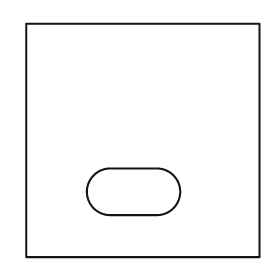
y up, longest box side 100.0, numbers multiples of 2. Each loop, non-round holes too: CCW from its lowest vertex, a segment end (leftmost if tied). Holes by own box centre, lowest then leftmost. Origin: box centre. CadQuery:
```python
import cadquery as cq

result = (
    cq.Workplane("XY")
    .moveTo(-50.0, -50.0)
    .lineTo(50.0, -50.0)
    .lineTo(50.0, 50.0)
    .lineTo(-50.0, 50.0)
    .close()
    .moveTo(-14.0, -32.0)
    .lineTo(6.0, -32.0)
    .threePointArc((16.0, -22.0), (6.0, -12.0))
    .lineTo(-14.0, -12.0)
    .threePointArc((-24.0, -22.0), (-14.0, -32.0))
    .close()
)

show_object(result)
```